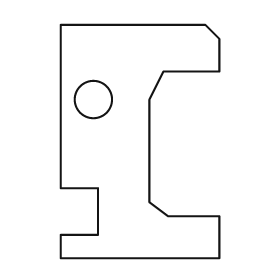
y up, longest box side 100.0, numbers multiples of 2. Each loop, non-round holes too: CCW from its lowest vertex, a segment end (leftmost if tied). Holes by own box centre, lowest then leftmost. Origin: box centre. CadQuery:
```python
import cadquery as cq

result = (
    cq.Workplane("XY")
    .moveTo(-34.0, -50.0)
    .lineTo(34.0, -50.0)
    .lineTo(34.0, -32.0)
    .lineTo(12.0, -32.0)
    .lineTo(4.0, -26.0)
    .lineTo(4.0, 18.0)
    .lineTo(10.0, 30.0)
    .lineTo(34.0, 30.0)
    .lineTo(34.0, 44.0)
    .lineTo(28.0, 50.0)
    .lineTo(-34.0, 50.0)
    .lineTo(-34.0, -20.0)
    .lineTo(-18.0, -20.0)
    .lineTo(-18.0, -40.0)
    .lineTo(-34.0, -40.0)
    .close()
    .moveTo(-20.0, 18.0)
    .circle(8.0)
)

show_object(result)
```